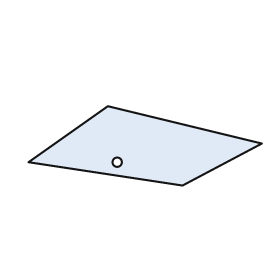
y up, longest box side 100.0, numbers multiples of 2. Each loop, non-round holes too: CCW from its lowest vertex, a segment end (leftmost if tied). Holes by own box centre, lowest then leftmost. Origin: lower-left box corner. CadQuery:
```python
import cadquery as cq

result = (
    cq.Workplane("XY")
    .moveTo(66.0, 0.0)
    .lineTo(100.0, 18.0)
    .lineTo(34.0, 34.0)
    .lineTo(0.0, 10.0)
    .close()
    .moveTo(38.0, 10.0)
    .circle(2.0)
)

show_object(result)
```